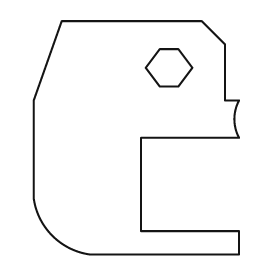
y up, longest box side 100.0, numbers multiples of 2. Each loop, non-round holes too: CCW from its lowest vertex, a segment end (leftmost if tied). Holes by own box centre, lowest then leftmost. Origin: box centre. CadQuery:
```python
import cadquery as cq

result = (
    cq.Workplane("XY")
    .moveTo(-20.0, -50.0)
    .lineTo(44.0, -50.0)
    .lineTo(44.0, -40.0)
    .lineTo(2.0, -40.0)
    .lineTo(2.0, 0.0)
    .lineTo(44.0, 0.0)
    .threePointArc((42.0, 8.0), (44.0, 16.0))
    .lineTo(38.0, 16.0)
    .lineTo(38.0, 40.0)
    .lineTo(28.0, 50.0)
    .lineTo(-32.0, 50.0)
    .lineTo(-44.0, 16.0)
    .lineTo(-44.0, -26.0)
    .threePointArc((-36.0, -42.0), (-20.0, -50.0))
    .close()
    .moveTo(10.0, 22.0)
    .lineTo(18.0, 22.0)
    .lineTo(24.0, 30.0)
    .lineTo(18.0, 38.0)
    .lineTo(10.0, 38.0)
    .lineTo(4.0, 30.0)
    .close()
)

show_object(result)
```